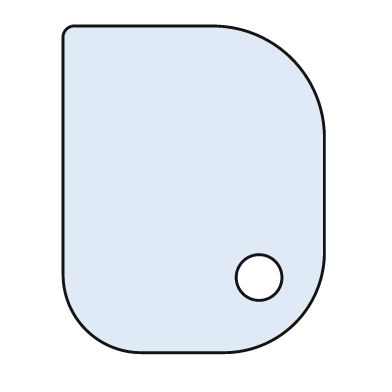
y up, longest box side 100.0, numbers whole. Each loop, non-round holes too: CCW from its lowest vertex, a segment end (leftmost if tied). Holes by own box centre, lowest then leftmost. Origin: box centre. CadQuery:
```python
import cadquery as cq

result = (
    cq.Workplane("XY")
    .moveTo(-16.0, -50.0)
    .lineTo(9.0, -50.0)
    .threePointArc((31.0, -41.0), (40.0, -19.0))
    .lineTo(40.0, 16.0)
    .threePointArc((30.0, 40.0), (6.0, 50.0))
    .lineTo(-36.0, 50.0)
    .threePointArc((-39.0, 49.0), (-40.0, 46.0))
    .lineTo(-40.0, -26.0)
    .threePointArc((-33.0, -43.0), (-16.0, -50.0))
    .close()
    .moveTo(20.0, -27.0)
    .circle(7.0)
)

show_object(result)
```